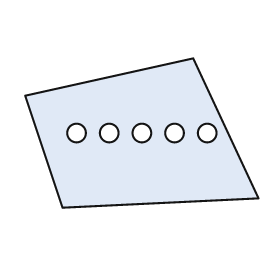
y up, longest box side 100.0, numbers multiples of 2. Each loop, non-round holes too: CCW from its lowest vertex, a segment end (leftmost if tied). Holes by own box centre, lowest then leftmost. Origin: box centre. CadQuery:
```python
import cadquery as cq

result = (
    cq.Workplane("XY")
    .moveTo(-34.0, -32.0)
    .lineTo(50.0, -28.0)
    .lineTo(22.0, 32.0)
    .lineTo(-50.0, 16.0)
    .close()
    .moveTo(-28.0, 0.0)
    .circle(4.0)
    .moveTo(-14.0, 0.0)
    .circle(4.0)
    .moveTo(0.0, 0.0)
    .circle(4.0)
    .moveTo(14.0, 0.0)
    .circle(4.0)
    .moveTo(28.0, 0.0)
    .circle(4.0)
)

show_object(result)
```